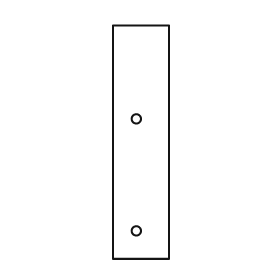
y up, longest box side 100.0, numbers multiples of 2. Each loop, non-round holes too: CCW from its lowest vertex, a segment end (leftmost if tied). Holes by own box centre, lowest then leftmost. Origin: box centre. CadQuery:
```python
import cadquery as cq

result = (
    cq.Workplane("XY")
    .moveTo(-12.0, -50.0)
    .lineTo(12.0, -50.0)
    .lineTo(12.0, 50.0)
    .lineTo(-12.0, 50.0)
    .close()
    .moveTo(-2.0, -38.0)
    .circle(2.0)
    .moveTo(-2.0, 10.0)
    .circle(2.0)
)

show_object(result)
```